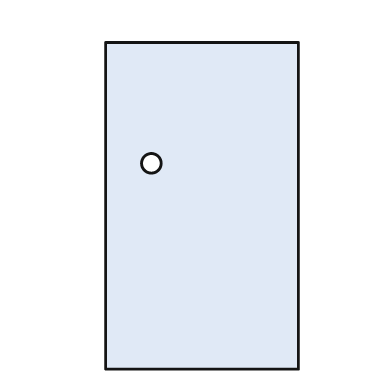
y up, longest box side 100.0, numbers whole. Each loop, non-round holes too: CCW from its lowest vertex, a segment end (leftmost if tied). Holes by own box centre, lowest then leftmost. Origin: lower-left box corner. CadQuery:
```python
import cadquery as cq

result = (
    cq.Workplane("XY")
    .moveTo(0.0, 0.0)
    .lineTo(59.0, 0.0)
    .lineTo(59.0, 100.0)
    .lineTo(0.0, 100.0)
    .close()
    .moveTo(14.0, 63.0)
    .circle(3.0)
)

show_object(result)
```